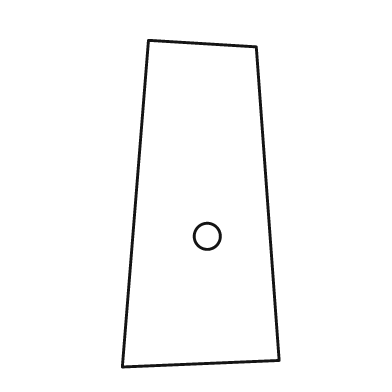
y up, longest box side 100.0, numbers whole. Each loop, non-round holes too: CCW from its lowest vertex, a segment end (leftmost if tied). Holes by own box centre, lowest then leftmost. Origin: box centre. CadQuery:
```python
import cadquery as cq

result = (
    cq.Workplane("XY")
    .moveTo(-24.0, -50.0)
    .lineTo(24.0, -48.0)
    .lineTo(17.0, 48.0)
    .lineTo(-16.0, 50.0)
    .close()
    .moveTo(2.0, -10.0)
    .circle(4.0)
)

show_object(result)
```